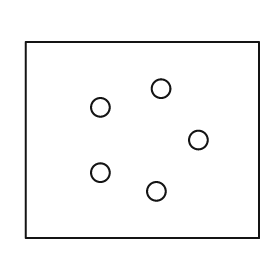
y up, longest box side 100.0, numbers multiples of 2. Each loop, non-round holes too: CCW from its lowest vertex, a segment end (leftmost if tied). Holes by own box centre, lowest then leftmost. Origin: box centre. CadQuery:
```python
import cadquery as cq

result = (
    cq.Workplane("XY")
    .moveTo(-50.0, -42.0)
    .lineTo(50.0, -42.0)
    .lineTo(50.0, 42.0)
    .lineTo(-50.0, 42.0)
    .close()
    .moveTo(6.0, -22.0)
    .circle(4.0)
    .moveTo(-18.0, -14.0)
    .circle(4.0)
    .moveTo(24.0, 0.0)
    .circle(4.0)
    .moveTo(-18.0, 14.0)
    .circle(4.0)
    .moveTo(8.0, 22.0)
    .circle(4.0)
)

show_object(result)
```